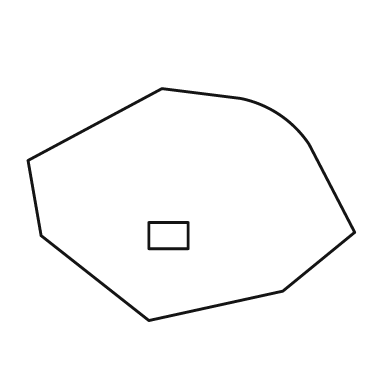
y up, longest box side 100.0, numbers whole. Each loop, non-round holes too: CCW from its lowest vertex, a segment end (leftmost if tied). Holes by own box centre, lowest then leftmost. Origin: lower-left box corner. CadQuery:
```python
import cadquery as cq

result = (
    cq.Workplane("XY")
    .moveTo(37.0, 0.0)
    .lineTo(78.0, 9.0)
    .lineTo(100.0, 27.0)
    .lineTo(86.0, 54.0)
    .threePointArc((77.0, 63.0), (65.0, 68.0))
    .lineTo(41.0, 71.0)
    .lineTo(0.0, 49.0)
    .lineTo(4.0, 26.0)
    .close()
    .moveTo(37.0, 22.0)
    .lineTo(49.0, 22.0)
    .lineTo(49.0, 30.0)
    .lineTo(37.0, 30.0)
    .close()
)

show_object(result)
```